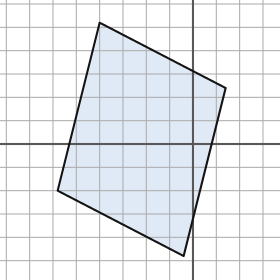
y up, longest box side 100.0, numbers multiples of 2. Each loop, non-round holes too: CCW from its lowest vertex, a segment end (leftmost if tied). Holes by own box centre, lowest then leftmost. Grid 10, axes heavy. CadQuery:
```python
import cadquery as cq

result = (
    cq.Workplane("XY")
    .moveTo(-4.0, -48.0)
    .lineTo(14.0, 24.0)
    .lineTo(-40.0, 52.0)
    .lineTo(-58.0, -20.0)
    .close()
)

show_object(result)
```